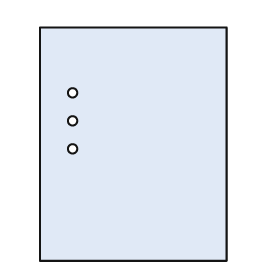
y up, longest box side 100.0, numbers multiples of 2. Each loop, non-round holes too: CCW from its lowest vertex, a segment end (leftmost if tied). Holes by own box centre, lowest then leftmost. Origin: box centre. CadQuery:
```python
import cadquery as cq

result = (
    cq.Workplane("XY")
    .moveTo(-40.0, -50.0)
    .lineTo(40.0, -50.0)
    .lineTo(40.0, 50.0)
    .lineTo(-40.0, 50.0)
    .close()
    .moveTo(-26.0, -2.0)
    .circle(2.0)
    .moveTo(-26.0, 10.0)
    .circle(2.0)
    .moveTo(-26.0, 22.0)
    .circle(2.0)
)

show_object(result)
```